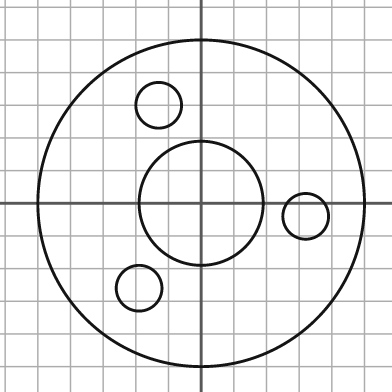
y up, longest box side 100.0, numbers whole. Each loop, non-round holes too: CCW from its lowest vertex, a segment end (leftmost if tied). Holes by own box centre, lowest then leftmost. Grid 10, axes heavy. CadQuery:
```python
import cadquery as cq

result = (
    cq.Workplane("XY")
    .moveTo(0.0, 0.0)
    .circle(50.0)
    .moveTo(-19.0, -26.0)
    .circle(7.0)
    .moveTo(32.0, -4.0)
    .circle(7.0)
    .moveTo(0.0, 0.0)
    .circle(19.0)
    .moveTo(-13.0, 30.0)
    .circle(7.0)
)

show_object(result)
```